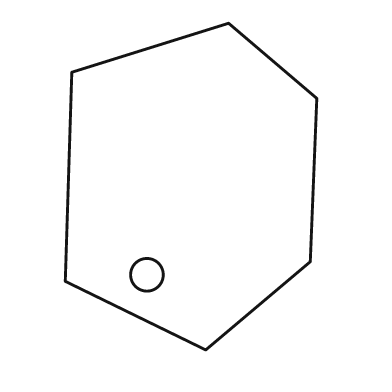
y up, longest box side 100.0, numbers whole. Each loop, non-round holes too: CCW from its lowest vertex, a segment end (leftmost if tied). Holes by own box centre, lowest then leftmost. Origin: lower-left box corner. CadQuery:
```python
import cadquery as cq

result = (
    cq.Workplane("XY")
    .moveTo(43.0, 0.0)
    .lineTo(75.0, 27.0)
    .lineTo(77.0, 77.0)
    .lineTo(50.0, 100.0)
    .lineTo(2.0, 85.0)
    .lineTo(0.0, 21.0)
    .close()
    .moveTo(25.0, 23.0)
    .circle(5.0)
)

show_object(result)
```